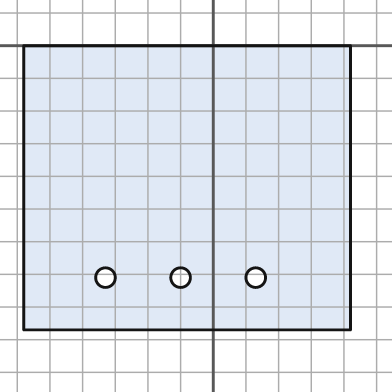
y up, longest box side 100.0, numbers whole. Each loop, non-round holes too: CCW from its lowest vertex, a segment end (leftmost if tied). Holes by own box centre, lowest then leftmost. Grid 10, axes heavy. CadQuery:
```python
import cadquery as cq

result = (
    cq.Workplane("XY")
    .moveTo(-58.0, -87.0)
    .lineTo(42.0, -87.0)
    .lineTo(42.0, 0.0)
    .lineTo(-58.0, 0.0)
    .close()
    .moveTo(-33.0, -71.0)
    .circle(3.0)
    .moveTo(-10.0, -71.0)
    .circle(3.0)
    .moveTo(13.0, -71.0)
    .circle(3.0)
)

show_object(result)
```